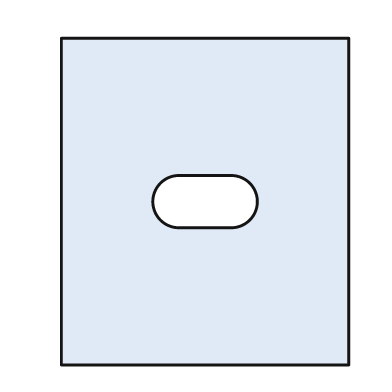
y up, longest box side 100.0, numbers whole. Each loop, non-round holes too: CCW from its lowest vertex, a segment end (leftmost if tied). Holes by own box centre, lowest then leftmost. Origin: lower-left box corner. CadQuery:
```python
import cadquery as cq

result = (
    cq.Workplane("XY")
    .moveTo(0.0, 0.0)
    .lineTo(88.0, 0.0)
    .lineTo(88.0, 100.0)
    .lineTo(0.0, 100.0)
    .close()
    .moveTo(36.0, 42.0)
    .lineTo(52.0, 42.0)
    .threePointArc((60.0, 50.0), (52.0, 58.0))
    .lineTo(36.0, 58.0)
    .threePointArc((28.0, 50.0), (36.0, 42.0))
    .close()
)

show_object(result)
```